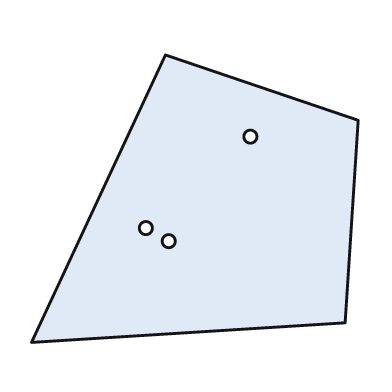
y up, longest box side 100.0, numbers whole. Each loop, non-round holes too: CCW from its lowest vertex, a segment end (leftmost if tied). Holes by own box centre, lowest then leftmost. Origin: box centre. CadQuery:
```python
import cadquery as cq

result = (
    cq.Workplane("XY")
    .moveTo(-50.0, -44.0)
    .lineTo(46.0, -38.0)
    .lineTo(50.0, 24.0)
    .lineTo(-9.0, 44.0)
    .close()
    .moveTo(-8.0, -13.0)
    .circle(2.0)
    .moveTo(-15.0, -9.0)
    .circle(2.0)
    .moveTo(17.0, 19.0)
    .circle(2.0)
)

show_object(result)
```